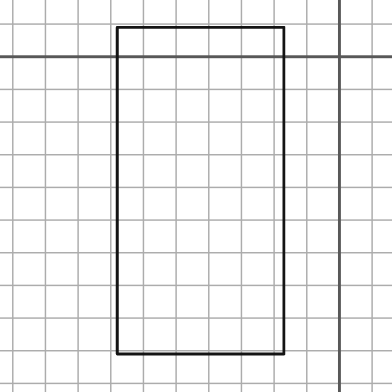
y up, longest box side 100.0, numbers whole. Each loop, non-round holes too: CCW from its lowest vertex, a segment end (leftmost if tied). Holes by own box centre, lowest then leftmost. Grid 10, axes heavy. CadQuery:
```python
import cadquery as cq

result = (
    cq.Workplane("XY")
    .moveTo(-68.0, -91.0)
    .lineTo(-17.0, -91.0)
    .lineTo(-17.0, 9.0)
    .lineTo(-68.0, 9.0)
    .close()
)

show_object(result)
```